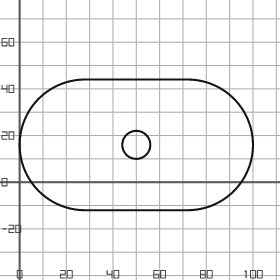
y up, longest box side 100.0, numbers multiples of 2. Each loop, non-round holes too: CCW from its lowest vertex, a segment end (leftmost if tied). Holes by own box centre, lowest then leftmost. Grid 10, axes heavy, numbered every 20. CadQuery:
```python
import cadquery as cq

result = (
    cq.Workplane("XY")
    .moveTo(28.0, -12.0)
    .lineTo(72.0, -12.0)
    .threePointArc((100.0, 16.0), (72.0, 44.0))
    .lineTo(28.0, 44.0)
    .threePointArc((0.0, 16.0), (28.0, -12.0))
    .close()
    .moveTo(50.0, 16.0)
    .circle(6.0)
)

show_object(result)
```